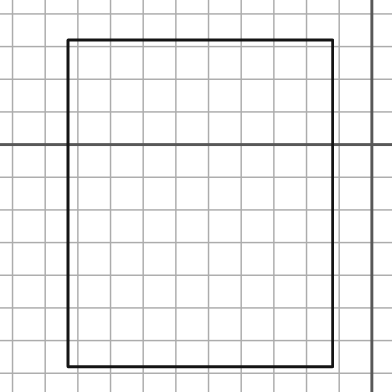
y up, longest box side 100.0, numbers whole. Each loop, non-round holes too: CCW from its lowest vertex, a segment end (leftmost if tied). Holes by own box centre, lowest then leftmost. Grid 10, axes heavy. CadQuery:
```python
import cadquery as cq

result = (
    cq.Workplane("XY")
    .moveTo(-93.0, -68.0)
    .lineTo(-12.0, -68.0)
    .lineTo(-12.0, 32.0)
    .lineTo(-93.0, 32.0)
    .close()
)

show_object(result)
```